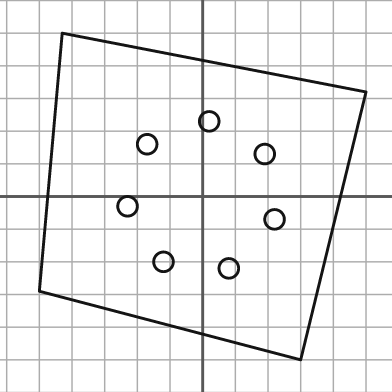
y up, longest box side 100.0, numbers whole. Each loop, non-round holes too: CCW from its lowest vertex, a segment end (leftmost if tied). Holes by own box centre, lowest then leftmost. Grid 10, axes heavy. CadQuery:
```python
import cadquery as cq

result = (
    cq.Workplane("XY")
    .moveTo(30.0, -50.0)
    .lineTo(50.0, 32.0)
    .lineTo(-43.0, 50.0)
    .lineTo(-50.0, -29.0)
    .close()
    .moveTo(8.0, -22.0)
    .circle(3.0)
    .moveTo(-12.0, -20.0)
    .circle(3.0)
    .moveTo(22.0, -7.0)
    .circle(3.0)
    .moveTo(-23.0, -3.0)
    .circle(3.0)
    .moveTo(19.0, 13.0)
    .circle(3.0)
    .moveTo(-17.0, 16.0)
    .circle(3.0)
    .moveTo(2.0, 23.0)
    .circle(3.0)
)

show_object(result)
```